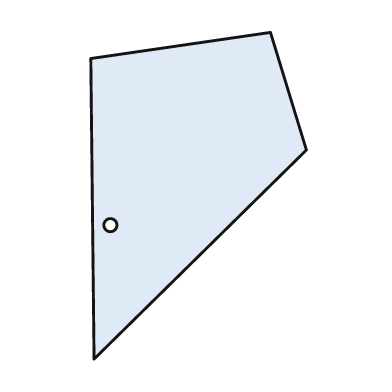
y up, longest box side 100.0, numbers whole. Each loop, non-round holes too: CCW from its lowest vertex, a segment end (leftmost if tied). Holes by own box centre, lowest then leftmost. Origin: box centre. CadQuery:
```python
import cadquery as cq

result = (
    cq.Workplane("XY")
    .moveTo(-32.0, -50.0)
    .lineTo(33.0, 14.0)
    .lineTo(22.0, 50.0)
    .lineTo(-33.0, 42.0)
    .close()
    .moveTo(-27.0, -9.0)
    .circle(2.0)
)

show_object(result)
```